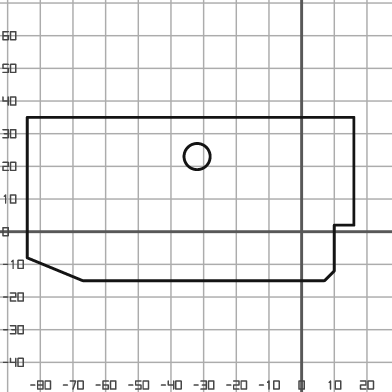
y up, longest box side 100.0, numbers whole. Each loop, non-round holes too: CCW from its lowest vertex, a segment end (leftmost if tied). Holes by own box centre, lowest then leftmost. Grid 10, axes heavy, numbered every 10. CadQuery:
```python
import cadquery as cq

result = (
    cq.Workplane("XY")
    .moveTo(-67.0, -15.0)
    .lineTo(7.0, -15.0)
    .lineTo(10.0, -12.0)
    .lineTo(10.0, 2.0)
    .lineTo(16.0, 2.0)
    .lineTo(16.0, 35.0)
    .lineTo(-84.0, 35.0)
    .lineTo(-84.0, -8.0)
    .close()
    .moveTo(-32.0, 23.0)
    .circle(4.0)
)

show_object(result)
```